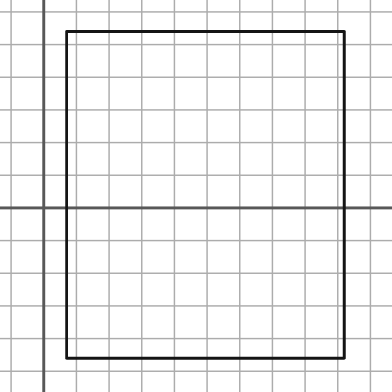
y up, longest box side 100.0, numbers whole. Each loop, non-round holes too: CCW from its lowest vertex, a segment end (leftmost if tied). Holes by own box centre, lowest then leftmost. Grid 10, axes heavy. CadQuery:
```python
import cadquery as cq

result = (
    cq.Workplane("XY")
    .moveTo(7.0, -46.0)
    .lineTo(92.0, -46.0)
    .lineTo(92.0, 54.0)
    .lineTo(7.0, 54.0)
    .close()
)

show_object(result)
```